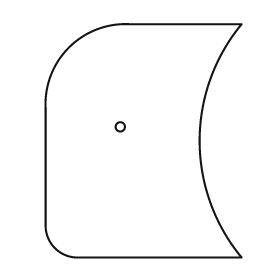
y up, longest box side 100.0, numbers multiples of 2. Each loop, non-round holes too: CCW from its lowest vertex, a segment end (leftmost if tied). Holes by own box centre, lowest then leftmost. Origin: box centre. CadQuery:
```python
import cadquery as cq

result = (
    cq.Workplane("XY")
    .moveTo(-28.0, -50.0)
    .lineTo(42.0, -50.0)
    .threePointArc((24.0, 0.0), (42.0, 50.0))
    .lineTo(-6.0, 50.0)
    .threePointArc((-32.0, 40.0), (-42.0, 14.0))
    .lineTo(-42.0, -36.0)
    .threePointArc((-38.0, -46.0), (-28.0, -50.0))
    .close()
    .moveTo(-10.0, 6.0)
    .circle(2.0)
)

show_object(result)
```